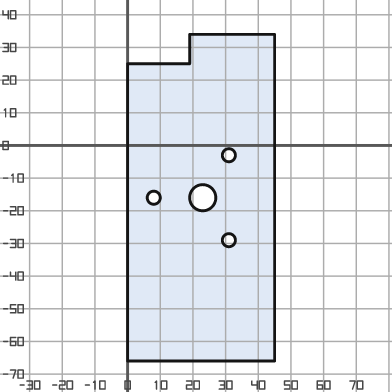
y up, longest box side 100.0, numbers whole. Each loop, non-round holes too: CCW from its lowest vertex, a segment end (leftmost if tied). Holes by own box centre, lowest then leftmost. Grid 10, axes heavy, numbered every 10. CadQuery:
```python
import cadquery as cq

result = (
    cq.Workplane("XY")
    .moveTo(0.0, -66.0)
    .lineTo(45.0, -66.0)
    .lineTo(45.0, 34.0)
    .lineTo(19.0, 34.0)
    .lineTo(19.0, 25.0)
    .lineTo(0.0, 25.0)
    .close()
    .moveTo(31.0, -29.0)
    .circle(2.0)
    .moveTo(8.0, -16.0)
    .circle(2.0)
    .moveTo(23.0, -16.0)
    .circle(4.0)
    .moveTo(31.0, -3.0)
    .circle(2.0)
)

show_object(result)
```